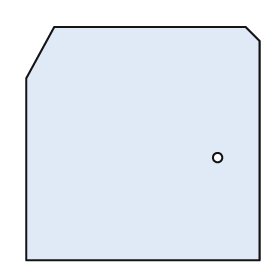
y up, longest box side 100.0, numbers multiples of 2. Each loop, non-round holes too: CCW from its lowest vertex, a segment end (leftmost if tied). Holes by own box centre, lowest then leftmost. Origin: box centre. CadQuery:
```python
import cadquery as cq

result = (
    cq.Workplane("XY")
    .moveTo(-50.0, -50.0)
    .lineTo(50.0, -50.0)
    .lineTo(50.0, 44.0)
    .lineTo(44.0, 50.0)
    .lineTo(-38.0, 50.0)
    .lineTo(-50.0, 28.0)
    .close()
    .moveTo(32.0, -6.0)
    .circle(2.0)
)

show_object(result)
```